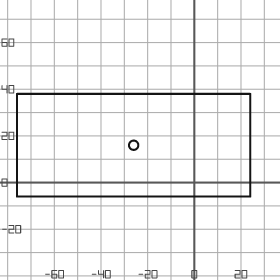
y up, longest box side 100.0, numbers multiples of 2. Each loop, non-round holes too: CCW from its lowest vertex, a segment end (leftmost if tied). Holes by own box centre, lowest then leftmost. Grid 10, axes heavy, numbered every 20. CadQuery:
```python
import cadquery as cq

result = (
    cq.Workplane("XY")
    .moveTo(-76.0, -6.0)
    .lineTo(24.0, -6.0)
    .lineTo(24.0, 38.0)
    .lineTo(-76.0, 38.0)
    .close()
    .moveTo(-26.0, 16.0)
    .circle(2.0)
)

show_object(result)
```